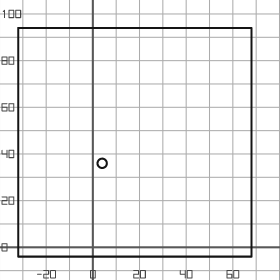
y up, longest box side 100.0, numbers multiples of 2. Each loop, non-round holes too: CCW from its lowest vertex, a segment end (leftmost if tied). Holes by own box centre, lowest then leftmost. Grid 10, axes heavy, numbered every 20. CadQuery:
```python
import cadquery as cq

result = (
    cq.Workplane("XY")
    .moveTo(-32.0, -4.0)
    .lineTo(68.0, -4.0)
    .lineTo(68.0, 94.0)
    .lineTo(-32.0, 94.0)
    .close()
    .moveTo(4.0, 36.0)
    .circle(2.0)
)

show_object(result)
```